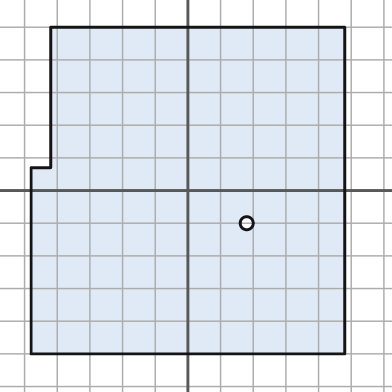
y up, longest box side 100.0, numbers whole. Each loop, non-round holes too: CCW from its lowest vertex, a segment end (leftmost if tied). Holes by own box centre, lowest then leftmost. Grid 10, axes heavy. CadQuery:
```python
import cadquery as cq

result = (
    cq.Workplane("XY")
    .moveTo(-48.0, -50.0)
    .lineTo(48.0, -50.0)
    .lineTo(48.0, 50.0)
    .lineTo(-42.0, 50.0)
    .lineTo(-42.0, 7.0)
    .lineTo(-48.0, 7.0)
    .close()
    .moveTo(18.0, -10.0)
    .circle(2.0)
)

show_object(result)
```